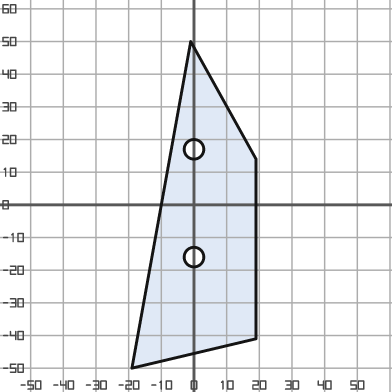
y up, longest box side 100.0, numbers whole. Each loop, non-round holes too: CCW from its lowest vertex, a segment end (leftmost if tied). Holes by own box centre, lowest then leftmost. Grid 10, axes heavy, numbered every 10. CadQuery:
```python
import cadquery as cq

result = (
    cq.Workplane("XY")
    .moveTo(-19.0, -50.0)
    .lineTo(19.0, -41.0)
    .lineTo(19.0, 14.0)
    .lineTo(-1.0, 50.0)
    .close()
    .moveTo(0.0, -16.0)
    .circle(3.0)
    .moveTo(0.0, 17.0)
    .circle(3.0)
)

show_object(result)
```